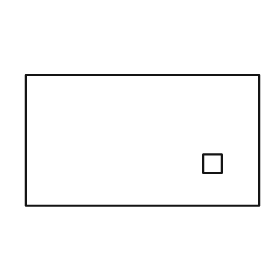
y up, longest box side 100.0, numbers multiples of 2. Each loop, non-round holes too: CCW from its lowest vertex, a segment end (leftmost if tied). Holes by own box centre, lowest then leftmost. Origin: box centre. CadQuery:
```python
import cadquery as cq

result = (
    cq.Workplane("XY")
    .moveTo(-50.0, -28.0)
    .lineTo(50.0, -28.0)
    .lineTo(50.0, 28.0)
    .lineTo(-50.0, 28.0)
    .close()
    .moveTo(26.0, -14.0)
    .lineTo(34.0, -14.0)
    .lineTo(34.0, -6.0)
    .lineTo(26.0, -6.0)
    .close()
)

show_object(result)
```